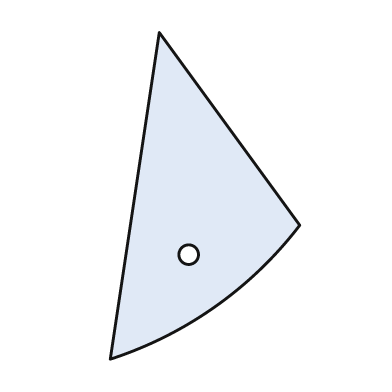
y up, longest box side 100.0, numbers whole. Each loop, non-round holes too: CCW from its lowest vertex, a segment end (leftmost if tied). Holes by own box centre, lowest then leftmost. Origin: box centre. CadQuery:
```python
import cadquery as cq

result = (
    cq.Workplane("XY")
    .moveTo(-29.0, -50.0)
    .threePointArc((3.0, -34.0), (29.0, -9.0))
    .lineTo(-14.0, 50.0)
    .close()
    .moveTo(-5.0, -18.0)
    .circle(3.0)
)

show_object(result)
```